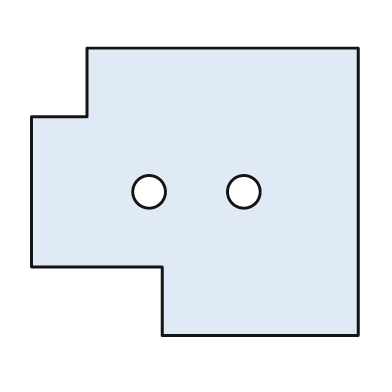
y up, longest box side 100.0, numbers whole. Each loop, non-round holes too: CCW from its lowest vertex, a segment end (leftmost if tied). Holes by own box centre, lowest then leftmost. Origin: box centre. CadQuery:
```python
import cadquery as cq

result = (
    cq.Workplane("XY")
    .moveTo(-10.0, -44.0)
    .lineTo(50.0, -44.0)
    .lineTo(50.0, 44.0)
    .lineTo(-33.0, 44.0)
    .lineTo(-33.0, 23.0)
    .lineTo(-50.0, 23.0)
    .lineTo(-50.0, -23.0)
    .lineTo(-10.0, -23.0)
    .close()
    .moveTo(-14.0, 0.0)
    .circle(5.0)
    .moveTo(15.0, 0.0)
    .circle(5.0)
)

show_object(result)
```